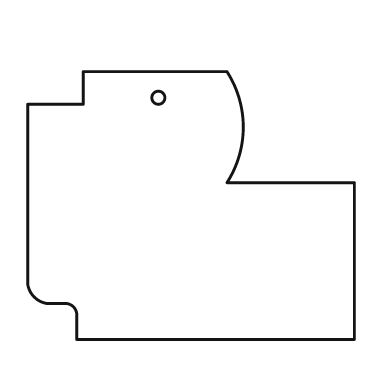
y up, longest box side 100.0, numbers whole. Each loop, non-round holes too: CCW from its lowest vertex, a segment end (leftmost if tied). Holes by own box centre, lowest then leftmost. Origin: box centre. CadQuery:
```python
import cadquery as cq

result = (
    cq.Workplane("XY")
    .moveTo(-35.0, -41.0)
    .lineTo(50.0, -41.0)
    .lineTo(50.0, 7.0)
    .lineTo(11.0, 7.0)
    .threePointArc((16.0, 24.0), (11.0, 41.0))
    .lineTo(-33.0, 41.0)
    .lineTo(-33.0, 31.0)
    .lineTo(-50.0, 31.0)
    .lineTo(-50.0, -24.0)
    .threePointArc((-48.0, -28.0), (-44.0, -30.0))
    .lineTo(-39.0, -30.0)
    .threePointArc((-36.0, -31.0), (-35.0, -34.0))
    .close()
    .moveTo(-10.0, 33.0)
    .circle(2.0)
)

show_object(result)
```